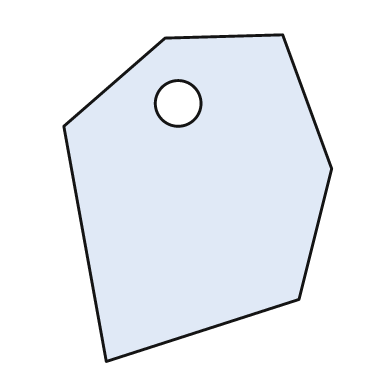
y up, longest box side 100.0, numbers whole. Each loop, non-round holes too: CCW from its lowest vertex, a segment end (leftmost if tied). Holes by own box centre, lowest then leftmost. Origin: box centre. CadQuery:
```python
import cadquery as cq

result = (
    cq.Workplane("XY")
    .moveTo(-28.0, -50.0)
    .lineTo(31.0, -31.0)
    .lineTo(41.0, 9.0)
    .lineTo(26.0, 50.0)
    .lineTo(-10.0, 49.0)
    .lineTo(-41.0, 22.0)
    .close()
    .moveTo(-6.0, 29.0)
    .circle(7.0)
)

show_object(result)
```